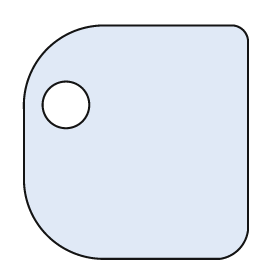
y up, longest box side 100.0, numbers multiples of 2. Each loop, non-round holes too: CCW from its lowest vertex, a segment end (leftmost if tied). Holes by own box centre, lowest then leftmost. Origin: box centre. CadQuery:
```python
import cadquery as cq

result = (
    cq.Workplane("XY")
    .moveTo(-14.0, -50.0)
    .lineTo(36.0, -50.0)
    .threePointArc((44.0, -46.0), (48.0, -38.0))
    .lineTo(48.0, 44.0)
    .threePointArc((46.0, 48.0), (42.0, 50.0))
    .lineTo(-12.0, 50.0)
    .threePointArc((-38.0, 40.0), (-48.0, 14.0))
    .lineTo(-48.0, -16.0)
    .threePointArc((-38.0, -40.0), (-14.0, -50.0))
    .close()
    .moveTo(-30.0, 16.0)
    .circle(10.0)
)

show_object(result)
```